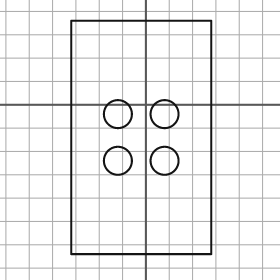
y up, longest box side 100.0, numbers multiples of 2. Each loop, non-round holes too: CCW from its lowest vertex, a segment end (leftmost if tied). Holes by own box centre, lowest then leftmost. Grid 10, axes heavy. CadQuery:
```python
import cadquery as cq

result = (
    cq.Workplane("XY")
    .moveTo(-32.0, -64.0)
    .lineTo(28.0, -64.0)
    .lineTo(28.0, 36.0)
    .lineTo(-32.0, 36.0)
    .close()
    .moveTo(-12.0, -24.0)
    .circle(6.0)
    .moveTo(8.0, -24.0)
    .circle(6.0)
    .moveTo(-12.0, -4.0)
    .circle(6.0)
    .moveTo(8.0, -4.0)
    .circle(6.0)
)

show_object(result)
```